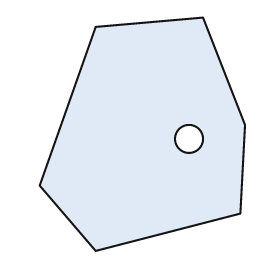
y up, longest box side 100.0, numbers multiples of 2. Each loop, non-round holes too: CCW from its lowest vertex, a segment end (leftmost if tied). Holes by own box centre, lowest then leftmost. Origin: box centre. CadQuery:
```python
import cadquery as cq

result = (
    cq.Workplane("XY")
    .moveTo(-20.0, -50.0)
    .lineTo(42.0, -34.0)
    .lineTo(44.0, 4.0)
    .lineTo(26.0, 50.0)
    .lineTo(-20.0, 46.0)
    .lineTo(-44.0, -22.0)
    .close()
    .moveTo(20.0, -2.0)
    .circle(6.0)
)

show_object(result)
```